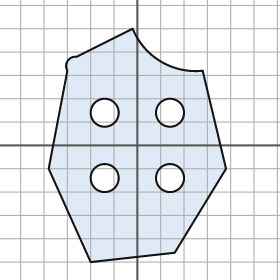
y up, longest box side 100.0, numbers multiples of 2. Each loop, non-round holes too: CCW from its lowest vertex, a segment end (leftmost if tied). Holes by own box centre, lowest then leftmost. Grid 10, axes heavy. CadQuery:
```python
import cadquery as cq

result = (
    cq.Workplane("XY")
    .moveTo(-20.0, -50.0)
    .lineTo(16.0, -46.0)
    .lineTo(38.0, -10.0)
    .lineTo(28.0, 32.0)
    .threePointArc((10.0, 36.0), (-2.0, 50.0))
    .lineTo(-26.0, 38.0)
    .threePointArc((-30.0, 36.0), (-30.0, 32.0))
    .lineTo(-38.0, -10.0)
    .close()
    .moveTo(-14.0, -14.0)
    .circle(6.0)
    .moveTo(14.0, -14.0)
    .circle(6.0)
    .moveTo(-14.0, 14.0)
    .circle(6.0)
    .moveTo(14.0, 14.0)
    .circle(6.0)
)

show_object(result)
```